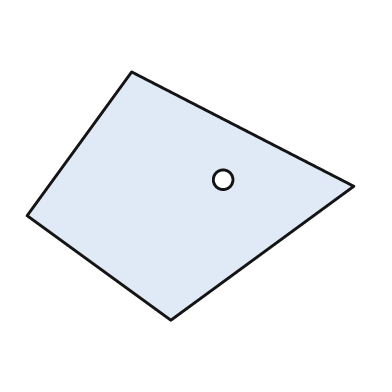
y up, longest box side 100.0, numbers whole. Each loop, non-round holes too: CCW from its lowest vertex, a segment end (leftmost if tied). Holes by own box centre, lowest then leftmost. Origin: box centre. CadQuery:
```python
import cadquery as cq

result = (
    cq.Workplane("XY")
    .moveTo(-6.0, -38.0)
    .lineTo(50.0, 3.0)
    .lineTo(-18.0, 38.0)
    .lineTo(-50.0, -6.0)
    .close()
    .moveTo(10.0, 5.0)
    .circle(3.0)
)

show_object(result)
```